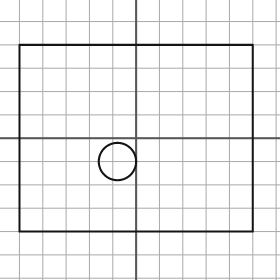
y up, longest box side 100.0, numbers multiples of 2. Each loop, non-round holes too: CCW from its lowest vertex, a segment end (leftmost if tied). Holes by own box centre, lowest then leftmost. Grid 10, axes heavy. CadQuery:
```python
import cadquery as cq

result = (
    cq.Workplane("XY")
    .moveTo(-50.0, -40.0)
    .lineTo(50.0, -40.0)
    .lineTo(50.0, 40.0)
    .lineTo(-50.0, 40.0)
    .close()
    .moveTo(-8.0, -10.0)
    .circle(8.0)
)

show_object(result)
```